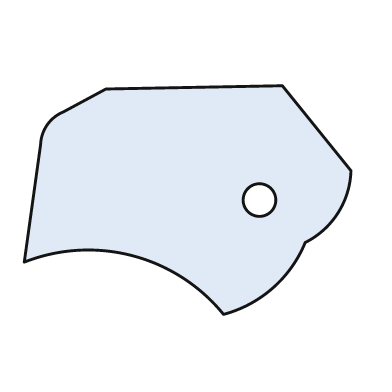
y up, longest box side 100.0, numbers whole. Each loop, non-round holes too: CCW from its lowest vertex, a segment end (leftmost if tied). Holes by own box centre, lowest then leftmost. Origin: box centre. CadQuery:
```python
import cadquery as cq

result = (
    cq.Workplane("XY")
    .moveTo(11.0, -35.0)
    .threePointArc((26.0, -27.0), (36.0, -13.0))
    .threePointArc((46.0, -4.0), (50.0, 9.0))
    .lineTo(29.0, 35.0)
    .lineTo(-25.0, 34.0)
    .lineTo(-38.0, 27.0)
    .threePointArc((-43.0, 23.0), (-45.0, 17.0))
    .lineTo(-50.0, -19.0)
    .threePointArc((-17.0, -17.0), (11.0, -35.0))
    .close()
    .moveTo(22.0, 0.0)
    .circle(5.0)
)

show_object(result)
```